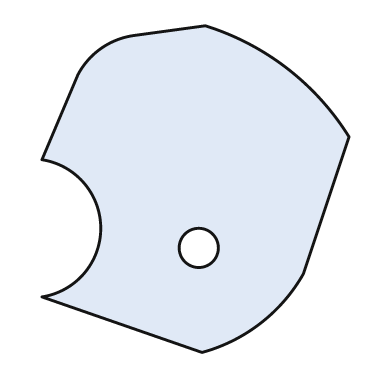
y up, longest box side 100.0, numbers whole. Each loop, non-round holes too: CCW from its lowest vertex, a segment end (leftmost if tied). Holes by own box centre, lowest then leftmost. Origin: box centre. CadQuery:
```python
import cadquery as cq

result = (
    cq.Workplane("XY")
    .moveTo(2.0, -50.0)
    .threePointArc((20.0, -41.0), (33.0, -26.0))
    .lineTo(47.0, 16.0)
    .threePointArc((28.0, 37.0), (3.0, 50.0))
    .lineTo(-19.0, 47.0)
    .threePointArc((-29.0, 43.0), (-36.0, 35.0))
    .lineTo(-47.0, 9.0)
    .threePointArc((-29.0, -12.0), (-47.0, -33.0))
    .close()
    .moveTo(1.0, -18.0)
    .circle(6.0)
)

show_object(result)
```